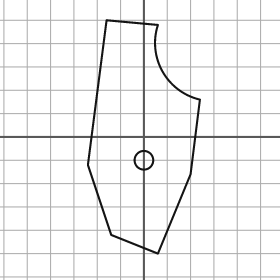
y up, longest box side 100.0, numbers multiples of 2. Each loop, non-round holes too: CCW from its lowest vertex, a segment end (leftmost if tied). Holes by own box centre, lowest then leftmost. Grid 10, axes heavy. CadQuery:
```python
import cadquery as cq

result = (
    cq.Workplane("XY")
    .moveTo(6.0, -50.0)
    .lineTo(20.0, -16.0)
    .lineTo(24.0, 16.0)
    .threePointArc((8.0, 28.0), (6.0, 48.0))
    .lineTo(-16.0, 50.0)
    .lineTo(-24.0, -12.0)
    .lineTo(-14.0, -42.0)
    .close()
    .moveTo(0.0, -10.0)
    .circle(4.0)
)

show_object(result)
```